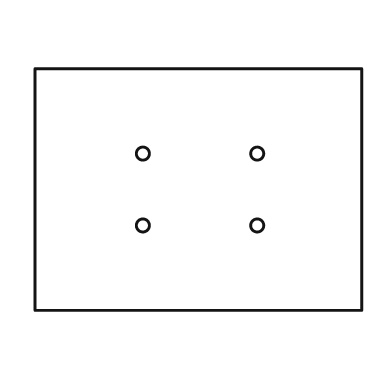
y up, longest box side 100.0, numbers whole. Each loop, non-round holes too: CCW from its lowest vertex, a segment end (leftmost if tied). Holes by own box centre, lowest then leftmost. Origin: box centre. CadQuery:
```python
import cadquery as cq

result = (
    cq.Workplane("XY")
    .moveTo(-50.0, -37.0)
    .lineTo(50.0, -37.0)
    .lineTo(50.0, 37.0)
    .lineTo(-50.0, 37.0)
    .close()
    .moveTo(-17.0, -11.0)
    .circle(2.0)
    .moveTo(18.0, -11.0)
    .circle(2.0)
    .moveTo(-17.0, 11.0)
    .circle(2.0)
    .moveTo(18.0, 11.0)
    .circle(2.0)
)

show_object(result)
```